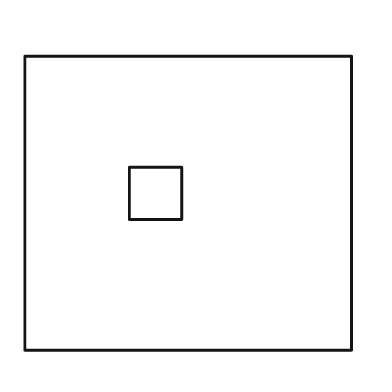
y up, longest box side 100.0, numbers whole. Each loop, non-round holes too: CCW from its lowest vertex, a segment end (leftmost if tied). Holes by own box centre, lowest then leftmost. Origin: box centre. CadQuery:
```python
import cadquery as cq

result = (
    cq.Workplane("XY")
    .moveTo(-50.0, -45.0)
    .lineTo(50.0, -45.0)
    .lineTo(50.0, 45.0)
    .lineTo(-50.0, 45.0)
    .close()
    .moveTo(-18.0, -5.0)
    .lineTo(-2.0, -5.0)
    .lineTo(-2.0, 11.0)
    .lineTo(-18.0, 11.0)
    .close()
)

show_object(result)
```